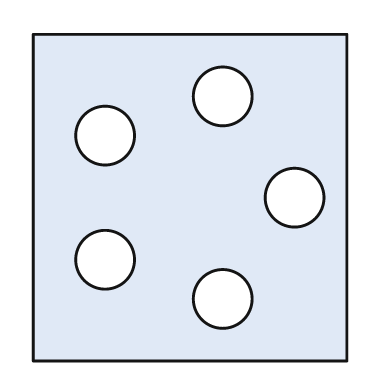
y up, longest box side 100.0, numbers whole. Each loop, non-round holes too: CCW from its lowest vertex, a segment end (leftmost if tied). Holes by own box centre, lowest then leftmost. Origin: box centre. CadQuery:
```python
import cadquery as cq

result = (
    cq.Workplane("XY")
    .moveTo(-48.0, -50.0)
    .lineTo(48.0, -50.0)
    .lineTo(48.0, 50.0)
    .lineTo(-48.0, 50.0)
    .close()
    .moveTo(10.0, -31.0)
    .circle(9.0)
    .moveTo(-26.0, -19.0)
    .circle(9.0)
    .moveTo(32.0, 0.0)
    .circle(9.0)
    .moveTo(-26.0, 19.0)
    .circle(9.0)
    .moveTo(10.0, 31.0)
    .circle(9.0)
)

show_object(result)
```